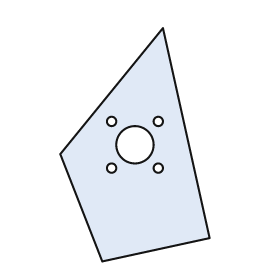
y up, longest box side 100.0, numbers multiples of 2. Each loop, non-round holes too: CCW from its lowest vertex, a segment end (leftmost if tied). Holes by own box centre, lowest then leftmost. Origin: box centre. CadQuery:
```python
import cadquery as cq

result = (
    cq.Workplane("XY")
    .moveTo(-14.0, -50.0)
    .lineTo(32.0, -40.0)
    .lineTo(12.0, 50.0)
    .lineTo(-32.0, -4.0)
    .close()
    .moveTo(-10.0, -10.0)
    .circle(2.0)
    .moveTo(10.0, -10.0)
    .circle(2.0)
    .moveTo(0.0, 0.0)
    .circle(8.0)
    .moveTo(-10.0, 10.0)
    .circle(2.0)
    .moveTo(10.0, 10.0)
    .circle(2.0)
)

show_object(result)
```